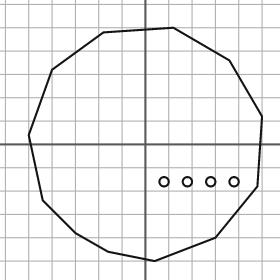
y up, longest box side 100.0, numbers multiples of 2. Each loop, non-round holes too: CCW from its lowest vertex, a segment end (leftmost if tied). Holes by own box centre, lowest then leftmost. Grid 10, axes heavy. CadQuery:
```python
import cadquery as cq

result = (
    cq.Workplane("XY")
    .moveTo(4.0, -50.0)
    .lineTo(30.0, -40.0)
    .lineTo(48.0, -18.0)
    .lineTo(50.0, 12.0)
    .lineTo(36.0, 36.0)
    .lineTo(12.0, 50.0)
    .lineTo(-18.0, 48.0)
    .lineTo(-40.0, 32.0)
    .lineTo(-50.0, 4.0)
    .lineTo(-44.0, -24.0)
    .lineTo(-30.0, -38.0)
    .lineTo(-16.0, -46.0)
    .close()
    .moveTo(8.0, -16.0)
    .circle(2.0)
    .moveTo(18.0, -16.0)
    .circle(2.0)
    .moveTo(28.0, -16.0)
    .circle(2.0)
    .moveTo(38.0, -16.0)
    .circle(2.0)
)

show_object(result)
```